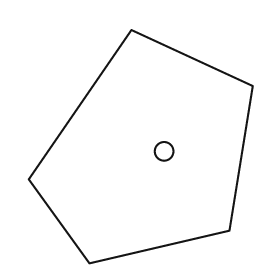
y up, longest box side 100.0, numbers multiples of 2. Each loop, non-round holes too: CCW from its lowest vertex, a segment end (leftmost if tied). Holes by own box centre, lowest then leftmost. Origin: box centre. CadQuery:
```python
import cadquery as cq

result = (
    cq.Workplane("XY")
    .moveTo(-22.0, -50.0)
    .lineTo(38.0, -36.0)
    .lineTo(48.0, 26.0)
    .lineTo(-4.0, 50.0)
    .lineTo(-48.0, -14.0)
    .close()
    .moveTo(10.0, -2.0)
    .circle(4.0)
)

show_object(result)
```